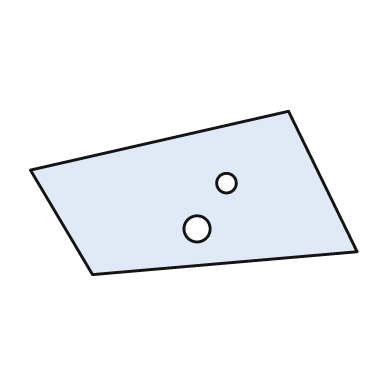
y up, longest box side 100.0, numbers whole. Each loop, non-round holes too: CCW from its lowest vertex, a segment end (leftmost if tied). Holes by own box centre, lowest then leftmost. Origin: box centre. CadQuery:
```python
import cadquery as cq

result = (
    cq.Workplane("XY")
    .moveTo(-31.0, -25.0)
    .lineTo(50.0, -18.0)
    .lineTo(29.0, 25.0)
    .lineTo(-50.0, 7.0)
    .close()
    .moveTo(1.0, -11.0)
    .circle(4.0)
    .moveTo(10.0, 3.0)
    .circle(3.0)
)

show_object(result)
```